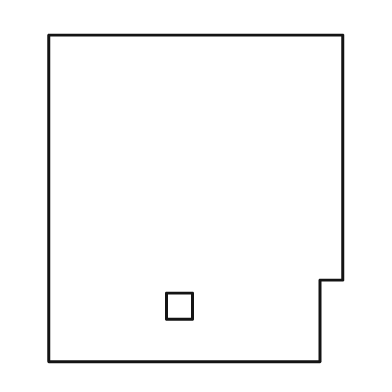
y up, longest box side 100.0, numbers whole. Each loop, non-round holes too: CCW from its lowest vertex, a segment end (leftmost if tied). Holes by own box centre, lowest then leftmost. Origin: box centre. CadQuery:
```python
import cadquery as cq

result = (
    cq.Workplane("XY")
    .moveTo(-45.0, -50.0)
    .lineTo(38.0, -50.0)
    .lineTo(38.0, -25.0)
    .lineTo(45.0, -25.0)
    .lineTo(45.0, 50.0)
    .lineTo(-45.0, 50.0)
    .close()
    .moveTo(-9.0, -37.0)
    .lineTo(-1.0, -37.0)
    .lineTo(-1.0, -29.0)
    .lineTo(-9.0, -29.0)
    .close()
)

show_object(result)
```